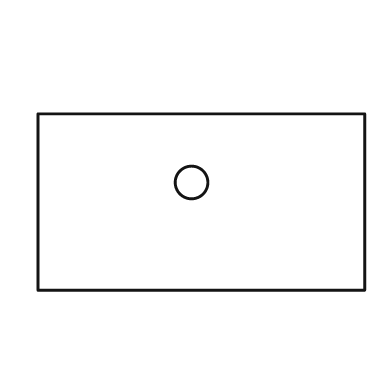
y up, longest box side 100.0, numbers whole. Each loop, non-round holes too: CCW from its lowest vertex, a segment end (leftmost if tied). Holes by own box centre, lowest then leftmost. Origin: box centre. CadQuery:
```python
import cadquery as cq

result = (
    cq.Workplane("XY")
    .moveTo(-50.0, -27.0)
    .lineTo(50.0, -27.0)
    .lineTo(50.0, 27.0)
    .lineTo(-50.0, 27.0)
    .close()
    .moveTo(-3.0, 6.0)
    .circle(5.0)
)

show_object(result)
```